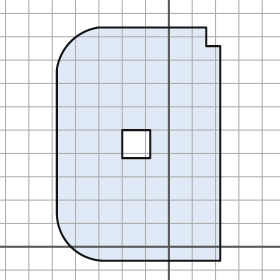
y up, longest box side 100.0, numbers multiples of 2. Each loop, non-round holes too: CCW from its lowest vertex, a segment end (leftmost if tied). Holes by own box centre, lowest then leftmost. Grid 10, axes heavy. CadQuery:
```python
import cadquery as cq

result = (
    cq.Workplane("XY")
    .moveTo(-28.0, -6.0)
    .lineTo(22.0, -6.0)
    .lineTo(22.0, 86.0)
    .lineTo(16.0, 86.0)
    .lineTo(16.0, 94.0)
    .lineTo(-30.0, 94.0)
    .threePointArc((-42.0, 88.0), (-48.0, 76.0))
    .lineTo(-48.0, 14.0)
    .threePointArc((-42.0, 0.0), (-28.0, -6.0))
    .close()
    .moveTo(-20.0, 38.0)
    .lineTo(-8.0, 38.0)
    .lineTo(-8.0, 50.0)
    .lineTo(-20.0, 50.0)
    .close()
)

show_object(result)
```